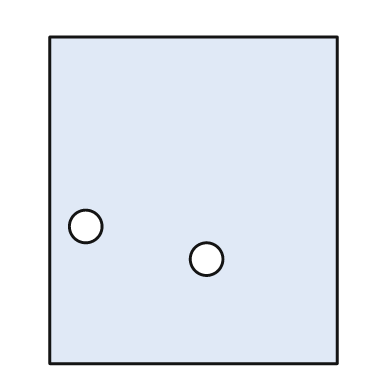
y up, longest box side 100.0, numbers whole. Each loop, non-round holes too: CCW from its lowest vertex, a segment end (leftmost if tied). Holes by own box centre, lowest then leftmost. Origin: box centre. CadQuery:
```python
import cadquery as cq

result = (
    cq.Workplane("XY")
    .moveTo(-44.0, -50.0)
    .lineTo(44.0, -50.0)
    .lineTo(44.0, 50.0)
    .lineTo(-44.0, 50.0)
    .close()
    .moveTo(4.0, -18.0)
    .circle(5.0)
    .moveTo(-33.0, -8.0)
    .circle(5.0)
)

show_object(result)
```